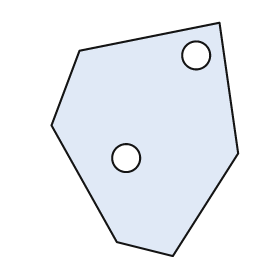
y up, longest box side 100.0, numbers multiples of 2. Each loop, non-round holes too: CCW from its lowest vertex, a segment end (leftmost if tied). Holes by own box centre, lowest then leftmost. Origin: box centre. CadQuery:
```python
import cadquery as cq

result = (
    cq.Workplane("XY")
    .moveTo(12.0, -50.0)
    .lineTo(40.0, -6.0)
    .lineTo(32.0, 50.0)
    .lineTo(-28.0, 38.0)
    .lineTo(-40.0, 6.0)
    .lineTo(-12.0, -44.0)
    .close()
    .moveTo(-8.0, -8.0)
    .circle(6.0)
    .moveTo(22.0, 36.0)
    .circle(6.0)
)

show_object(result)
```